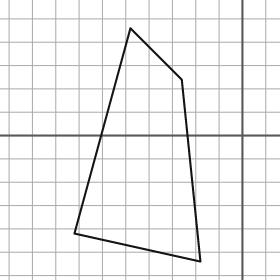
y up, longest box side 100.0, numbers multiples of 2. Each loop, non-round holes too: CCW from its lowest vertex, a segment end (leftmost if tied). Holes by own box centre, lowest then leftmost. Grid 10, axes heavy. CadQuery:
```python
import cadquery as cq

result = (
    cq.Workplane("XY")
    .moveTo(-18.0, -54.0)
    .lineTo(-26.0, 24.0)
    .lineTo(-48.0, 46.0)
    .lineTo(-72.0, -42.0)
    .close()
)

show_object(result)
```